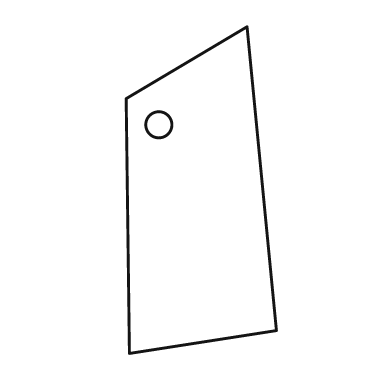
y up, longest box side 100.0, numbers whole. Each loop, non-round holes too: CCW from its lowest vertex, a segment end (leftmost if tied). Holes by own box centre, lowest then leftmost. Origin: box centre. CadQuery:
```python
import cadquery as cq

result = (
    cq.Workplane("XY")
    .moveTo(-22.0, -50.0)
    .lineTo(23.0, -43.0)
    .lineTo(14.0, 50.0)
    .lineTo(-23.0, 28.0)
    .close()
    .moveTo(-13.0, 20.0)
    .circle(4.0)
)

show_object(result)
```